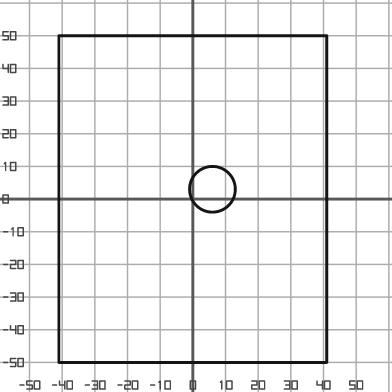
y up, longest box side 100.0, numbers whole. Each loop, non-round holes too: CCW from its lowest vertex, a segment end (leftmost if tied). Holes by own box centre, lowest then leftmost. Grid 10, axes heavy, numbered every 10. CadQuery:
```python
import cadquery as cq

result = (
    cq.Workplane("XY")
    .moveTo(-41.0, -50.0)
    .lineTo(41.0, -50.0)
    .lineTo(41.0, 50.0)
    .lineTo(-41.0, 50.0)
    .close()
    .moveTo(6.0, 3.0)
    .circle(7.0)
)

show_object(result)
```